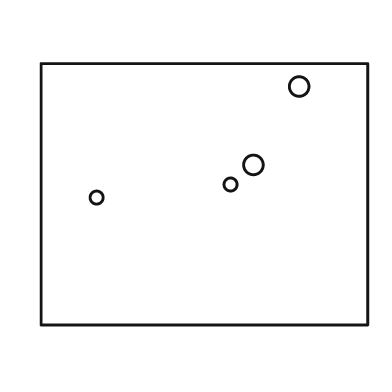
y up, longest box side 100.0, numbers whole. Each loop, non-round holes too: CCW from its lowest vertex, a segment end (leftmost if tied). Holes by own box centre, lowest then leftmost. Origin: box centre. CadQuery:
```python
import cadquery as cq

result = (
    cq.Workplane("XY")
    .moveTo(-50.0, -40.0)
    .lineTo(50.0, -40.0)
    .lineTo(50.0, 40.0)
    .lineTo(-50.0, 40.0)
    .close()
    .moveTo(-33.0, -1.0)
    .circle(2.0)
    .moveTo(8.0, 3.0)
    .circle(2.0)
    .moveTo(15.0, 9.0)
    .circle(3.0)
    .moveTo(29.0, 33.0)
    .circle(3.0)
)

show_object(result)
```